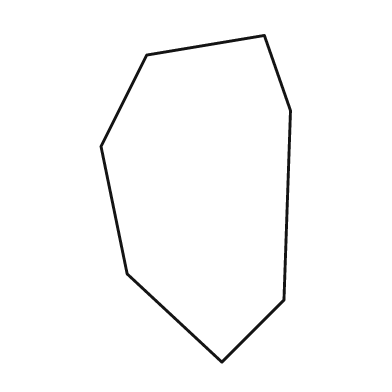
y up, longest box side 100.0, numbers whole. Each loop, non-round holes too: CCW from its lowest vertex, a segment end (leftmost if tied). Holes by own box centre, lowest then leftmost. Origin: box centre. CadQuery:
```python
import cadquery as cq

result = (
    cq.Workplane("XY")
    .moveTo(8.0, -50.0)
    .lineTo(27.0, -31.0)
    .lineTo(29.0, 27.0)
    .lineTo(21.0, 50.0)
    .lineTo(-15.0, 44.0)
    .lineTo(-29.0, 16.0)
    .lineTo(-21.0, -23.0)
    .close()
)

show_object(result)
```